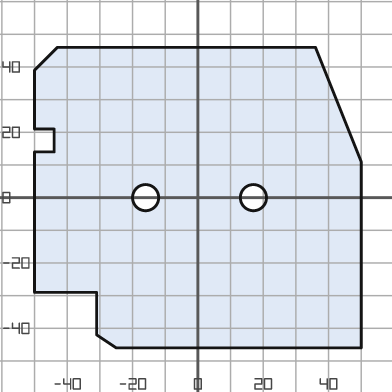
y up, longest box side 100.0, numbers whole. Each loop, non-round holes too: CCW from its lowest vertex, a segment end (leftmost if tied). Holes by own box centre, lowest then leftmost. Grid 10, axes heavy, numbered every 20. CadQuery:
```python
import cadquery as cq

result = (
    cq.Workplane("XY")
    .moveTo(-25.0, -46.0)
    .lineTo(50.0, -46.0)
    .lineTo(50.0, 11.0)
    .lineTo(36.0, 46.0)
    .lineTo(-43.0, 46.0)
    .lineTo(-50.0, 39.0)
    .lineTo(-50.0, 21.0)
    .lineTo(-44.0, 21.0)
    .lineTo(-44.0, 14.0)
    .lineTo(-50.0, 14.0)
    .lineTo(-50.0, -29.0)
    .lineTo(-31.0, -29.0)
    .lineTo(-31.0, -42.0)
    .close()
    .moveTo(-16.0, 0.0)
    .circle(4.0)
    .moveTo(17.0, 0.0)
    .circle(4.0)
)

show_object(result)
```